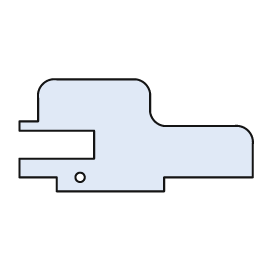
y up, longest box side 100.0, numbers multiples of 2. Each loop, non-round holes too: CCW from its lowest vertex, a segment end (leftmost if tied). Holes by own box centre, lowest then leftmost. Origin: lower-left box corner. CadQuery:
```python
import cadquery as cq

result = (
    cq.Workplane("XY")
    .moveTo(16.0, 0.0)
    .lineTo(62.0, 0.0)
    .lineTo(62.0, 6.0)
    .lineTo(100.0, 6.0)
    .lineTo(100.0, 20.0)
    .threePointArc((98.0, 26.0), (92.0, 28.0))
    .lineTo(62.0, 28.0)
    .threePointArc((58.0, 30.0), (56.0, 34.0))
    .lineTo(56.0, 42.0)
    .threePointArc((54.0, 46.0), (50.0, 48.0))
    .lineTo(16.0, 48.0)
    .threePointArc((10.0, 46.0), (8.0, 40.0))
    .lineTo(8.0, 30.0)
    .lineTo(0.0, 30.0)
    .lineTo(0.0, 26.0)
    .lineTo(32.0, 26.0)
    .lineTo(32.0, 14.0)
    .lineTo(0.0, 14.0)
    .lineTo(0.0, 6.0)
    .lineTo(16.0, 6.0)
    .close()
    .moveTo(26.0, 6.0)
    .circle(2.0)
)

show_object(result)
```